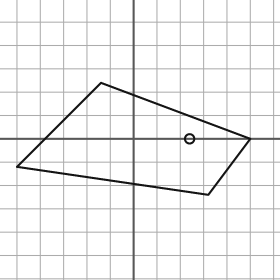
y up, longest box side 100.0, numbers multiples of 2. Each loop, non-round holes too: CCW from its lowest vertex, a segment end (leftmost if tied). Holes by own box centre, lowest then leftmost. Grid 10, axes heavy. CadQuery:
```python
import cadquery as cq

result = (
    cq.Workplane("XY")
    .moveTo(32.0, -24.0)
    .lineTo(50.0, 0.0)
    .lineTo(-14.0, 24.0)
    .lineTo(-50.0, -12.0)
    .close()
    .moveTo(24.0, 0.0)
    .circle(2.0)
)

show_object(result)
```